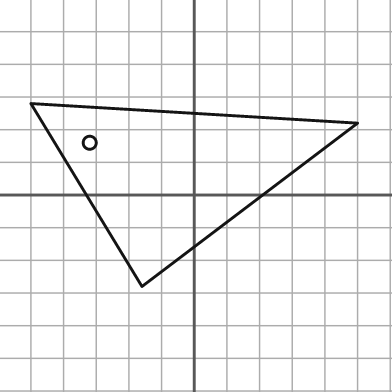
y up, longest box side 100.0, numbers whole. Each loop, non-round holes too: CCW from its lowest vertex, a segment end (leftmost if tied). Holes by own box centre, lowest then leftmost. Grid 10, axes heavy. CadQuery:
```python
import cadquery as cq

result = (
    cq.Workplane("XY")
    .moveTo(-16.0, -28.0)
    .lineTo(50.0, 22.0)
    .lineTo(-50.0, 28.0)
    .close()
    .moveTo(-32.0, 16.0)
    .circle(2.0)
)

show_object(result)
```